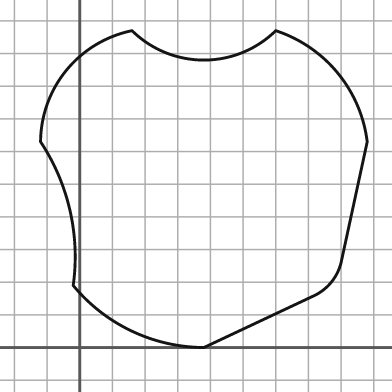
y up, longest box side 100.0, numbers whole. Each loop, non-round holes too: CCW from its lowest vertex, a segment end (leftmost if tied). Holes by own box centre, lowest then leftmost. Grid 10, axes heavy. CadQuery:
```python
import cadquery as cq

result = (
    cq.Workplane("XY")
    .moveTo(38.0, 0.0)
    .lineTo(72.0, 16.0)
    .threePointArc((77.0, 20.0), (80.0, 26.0))
    .lineTo(88.0, 63.0)
    .threePointArc((79.0, 84.0), (60.0, 97.0))
    .threePointArc((38.0, 88.0), (16.0, 97.0))
    .threePointArc((-4.0, 85.0), (-12.0, 63.0))
    .threePointArc((-3.0, 42.0), (-2.0, 19.0))
    .threePointArc((16.0, 5.0), (38.0, 0.0))
    .close()
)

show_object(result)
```